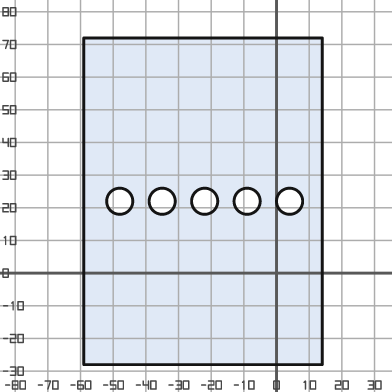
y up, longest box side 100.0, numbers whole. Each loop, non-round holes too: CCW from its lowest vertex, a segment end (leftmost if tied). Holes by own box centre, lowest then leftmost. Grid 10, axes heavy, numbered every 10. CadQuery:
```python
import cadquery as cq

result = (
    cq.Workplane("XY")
    .moveTo(-59.0, -28.0)
    .lineTo(14.0, -28.0)
    .lineTo(14.0, 72.0)
    .lineTo(-59.0, 72.0)
    .close()
    .moveTo(-48.0, 22.0)
    .circle(4.0)
    .moveTo(-35.0, 22.0)
    .circle(4.0)
    .moveTo(-22.0, 22.0)
    .circle(4.0)
    .moveTo(-9.0, 22.0)
    .circle(4.0)
    .moveTo(4.0, 22.0)
    .circle(4.0)
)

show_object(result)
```